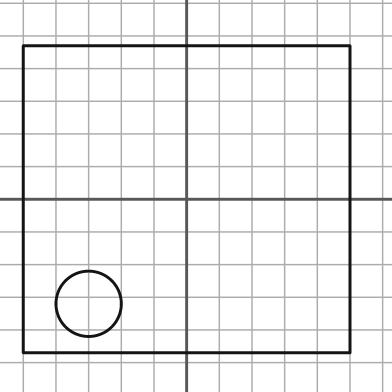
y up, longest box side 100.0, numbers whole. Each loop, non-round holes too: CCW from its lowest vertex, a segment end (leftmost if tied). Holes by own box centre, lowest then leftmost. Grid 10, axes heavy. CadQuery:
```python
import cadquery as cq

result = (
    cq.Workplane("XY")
    .moveTo(-50.0, -47.0)
    .lineTo(50.0, -47.0)
    .lineTo(50.0, 47.0)
    .lineTo(-50.0, 47.0)
    .close()
    .moveTo(-30.0, -32.0)
    .circle(10.0)
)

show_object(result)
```